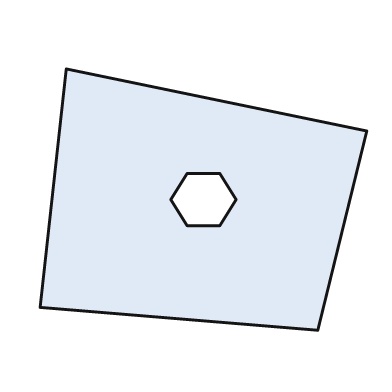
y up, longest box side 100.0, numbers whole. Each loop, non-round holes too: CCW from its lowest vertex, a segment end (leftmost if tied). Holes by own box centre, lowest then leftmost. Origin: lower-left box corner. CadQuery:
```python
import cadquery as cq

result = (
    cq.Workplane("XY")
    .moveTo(85.0, 0.0)
    .lineTo(100.0, 61.0)
    .lineTo(8.0, 80.0)
    .lineTo(0.0, 7.0)
    .close()
    .moveTo(45.0, 32.0)
    .lineTo(55.0, 32.0)
    .lineTo(60.0, 40.0)
    .lineTo(55.0, 48.0)
    .lineTo(45.0, 48.0)
    .lineTo(40.0, 40.0)
    .close()
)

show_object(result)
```